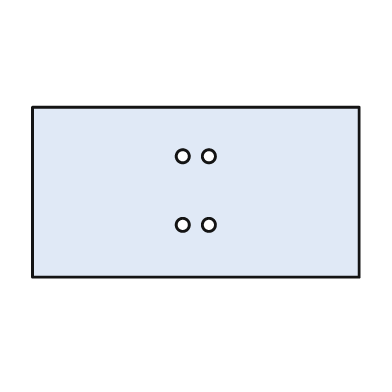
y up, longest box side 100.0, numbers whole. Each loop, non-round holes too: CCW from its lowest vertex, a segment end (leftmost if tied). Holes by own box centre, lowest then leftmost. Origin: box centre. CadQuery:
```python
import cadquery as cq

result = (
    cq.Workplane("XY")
    .moveTo(-50.0, -26.0)
    .lineTo(50.0, -26.0)
    .lineTo(50.0, 26.0)
    .lineTo(-50.0, 26.0)
    .close()
    .moveTo(-4.0, -10.0)
    .circle(2.0)
    .moveTo(4.0, -10.0)
    .circle(2.0)
    .moveTo(-4.0, 11.0)
    .circle(2.0)
    .moveTo(4.0, 11.0)
    .circle(2.0)
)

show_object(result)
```